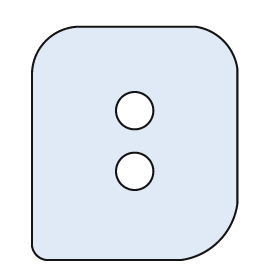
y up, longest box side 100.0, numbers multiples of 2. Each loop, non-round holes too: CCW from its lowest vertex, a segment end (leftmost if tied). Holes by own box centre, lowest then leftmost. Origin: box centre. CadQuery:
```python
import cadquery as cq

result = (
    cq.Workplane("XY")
    .moveTo(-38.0, -50.0)
    .lineTo(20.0, -50.0)
    .threePointArc((36.0, -42.0), (44.0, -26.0))
    .lineTo(44.0, 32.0)
    .threePointArc((38.0, 44.0), (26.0, 50.0))
    .lineTo(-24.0, 50.0)
    .threePointArc((-38.0, 44.0), (-44.0, 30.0))
    .lineTo(-44.0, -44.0)
    .threePointArc((-42.0, -48.0), (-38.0, -50.0))
    .close()
    .moveTo(0.0, -12.0)
    .circle(8.0)
    .moveTo(0.0, 14.0)
    .circle(8.0)
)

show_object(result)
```